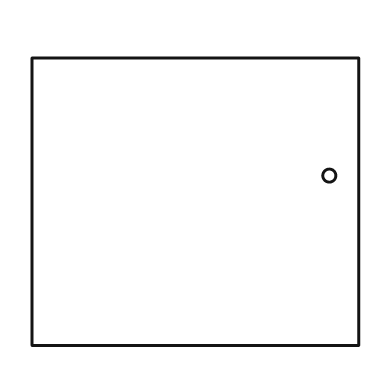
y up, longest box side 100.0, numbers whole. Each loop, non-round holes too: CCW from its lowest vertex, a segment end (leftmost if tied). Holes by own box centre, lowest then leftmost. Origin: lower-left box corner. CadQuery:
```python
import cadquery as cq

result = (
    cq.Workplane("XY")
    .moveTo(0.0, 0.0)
    .lineTo(100.0, 0.0)
    .lineTo(100.0, 88.0)
    .lineTo(0.0, 88.0)
    .close()
    .moveTo(91.0, 52.0)
    .circle(2.0)
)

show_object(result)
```